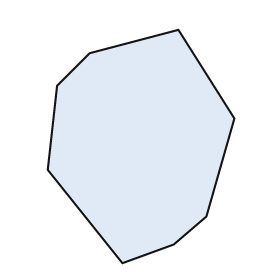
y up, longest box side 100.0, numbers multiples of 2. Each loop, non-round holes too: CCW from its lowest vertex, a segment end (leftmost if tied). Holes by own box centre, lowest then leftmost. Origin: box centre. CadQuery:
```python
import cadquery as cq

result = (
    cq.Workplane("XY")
    .moveTo(-8.0, -50.0)
    .lineTo(14.0, -42.0)
    .lineTo(28.0, -30.0)
    .lineTo(40.0, 12.0)
    .lineTo(16.0, 50.0)
    .lineTo(-22.0, 40.0)
    .lineTo(-36.0, 26.0)
    .lineTo(-40.0, -10.0)
    .close()
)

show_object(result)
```